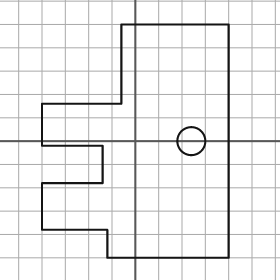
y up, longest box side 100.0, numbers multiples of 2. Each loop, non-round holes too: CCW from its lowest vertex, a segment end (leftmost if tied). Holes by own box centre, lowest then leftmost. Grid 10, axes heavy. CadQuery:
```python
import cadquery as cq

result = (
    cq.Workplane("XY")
    .moveTo(-12.0, -50.0)
    .lineTo(40.0, -50.0)
    .lineTo(40.0, 50.0)
    .lineTo(-6.0, 50.0)
    .lineTo(-6.0, 16.0)
    .lineTo(-40.0, 16.0)
    .lineTo(-40.0, -2.0)
    .lineTo(-14.0, -2.0)
    .lineTo(-14.0, -18.0)
    .lineTo(-40.0, -18.0)
    .lineTo(-40.0, -38.0)
    .lineTo(-12.0, -38.0)
    .close()
    .moveTo(24.0, 0.0)
    .circle(6.0)
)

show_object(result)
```